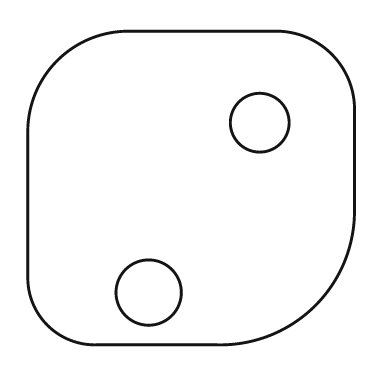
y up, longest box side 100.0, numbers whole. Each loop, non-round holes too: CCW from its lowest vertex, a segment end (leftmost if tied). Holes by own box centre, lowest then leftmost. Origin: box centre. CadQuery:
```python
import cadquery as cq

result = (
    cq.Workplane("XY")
    .moveTo(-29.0, -48.0)
    .lineTo(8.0, -48.0)
    .threePointArc((38.0, -36.0), (50.0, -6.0))
    .lineTo(50.0, 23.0)
    .threePointArc((43.0, 41.0), (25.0, 48.0))
    .lineTo(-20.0, 48.0)
    .threePointArc((-41.0, 39.0), (-50.0, 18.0))
    .lineTo(-50.0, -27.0)
    .threePointArc((-44.0, -42.0), (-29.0, -48.0))
    .close()
    .moveTo(-13.0, -32.0)
    .circle(10.0)
    .moveTo(21.0, 20.0)
    .circle(9.0)
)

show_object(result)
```